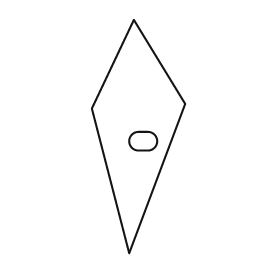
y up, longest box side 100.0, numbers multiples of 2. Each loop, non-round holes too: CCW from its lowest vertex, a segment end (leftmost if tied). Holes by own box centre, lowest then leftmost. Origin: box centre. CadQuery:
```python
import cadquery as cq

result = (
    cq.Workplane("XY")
    .moveTo(-4.0, -50.0)
    .lineTo(20.0, 14.0)
    .lineTo(-2.0, 50.0)
    .lineTo(-20.0, 12.0)
    .close()
    .moveTo(0.0, -6.0)
    .lineTo(4.0, -6.0)
    .threePointArc((8.0, -2.0), (4.0, 2.0))
    .lineTo(0.0, 2.0)
    .threePointArc((-4.0, -2.0), (0.0, -6.0))
    .close()
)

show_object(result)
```